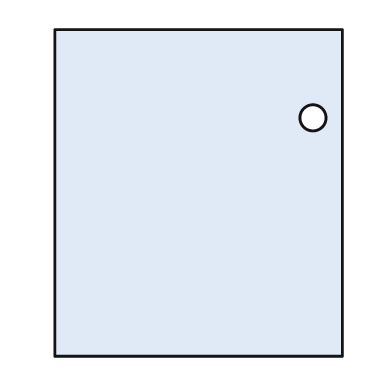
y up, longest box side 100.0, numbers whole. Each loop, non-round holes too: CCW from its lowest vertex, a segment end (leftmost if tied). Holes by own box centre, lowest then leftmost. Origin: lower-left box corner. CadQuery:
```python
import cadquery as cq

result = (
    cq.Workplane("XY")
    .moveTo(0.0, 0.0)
    .lineTo(88.0, 0.0)
    .lineTo(88.0, 100.0)
    .lineTo(0.0, 100.0)
    .close()
    .moveTo(79.0, 73.0)
    .circle(4.0)
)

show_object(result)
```